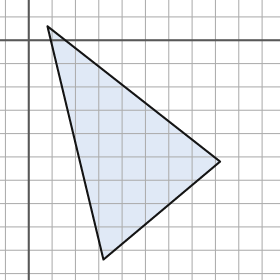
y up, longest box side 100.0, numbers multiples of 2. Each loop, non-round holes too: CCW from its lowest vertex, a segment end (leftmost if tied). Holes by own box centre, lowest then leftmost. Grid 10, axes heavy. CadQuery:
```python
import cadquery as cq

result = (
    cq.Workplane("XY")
    .moveTo(32.0, -94.0)
    .lineTo(82.0, -52.0)
    .lineTo(8.0, 6.0)
    .close()
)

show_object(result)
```